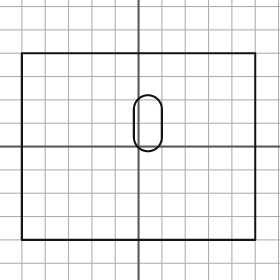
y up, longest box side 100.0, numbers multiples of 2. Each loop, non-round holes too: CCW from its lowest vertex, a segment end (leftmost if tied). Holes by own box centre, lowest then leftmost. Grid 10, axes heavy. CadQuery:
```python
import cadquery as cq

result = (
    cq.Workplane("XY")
    .moveTo(-50.0, -40.0)
    .lineTo(50.0, -40.0)
    .lineTo(50.0, 40.0)
    .lineTo(-50.0, 40.0)
    .close()
    .moveTo(-2.0, 4.0)
    .threePointArc((4.0, -2.0), (10.0, 4.0))
    .lineTo(10.0, 16.0)
    .threePointArc((4.0, 22.0), (-2.0, 16.0))
    .close()
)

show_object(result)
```